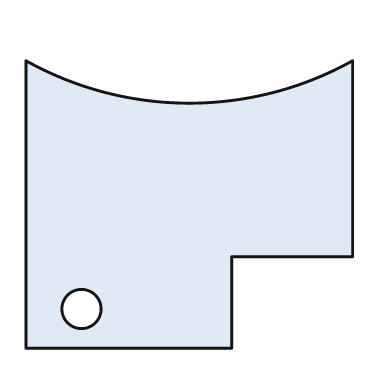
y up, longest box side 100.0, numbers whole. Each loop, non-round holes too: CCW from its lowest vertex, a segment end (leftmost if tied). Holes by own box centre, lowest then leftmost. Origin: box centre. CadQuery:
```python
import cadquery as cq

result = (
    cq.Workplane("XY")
    .moveTo(-50.0, -44.0)
    .lineTo(13.0, -44.0)
    .lineTo(13.0, -16.0)
    .lineTo(50.0, -16.0)
    .lineTo(50.0, 44.0)
    .threePointArc((0.0, 31.0), (-50.0, 44.0))
    .close()
    .moveTo(-33.0, -32.0)
    .circle(6.0)
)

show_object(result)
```